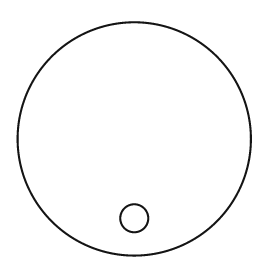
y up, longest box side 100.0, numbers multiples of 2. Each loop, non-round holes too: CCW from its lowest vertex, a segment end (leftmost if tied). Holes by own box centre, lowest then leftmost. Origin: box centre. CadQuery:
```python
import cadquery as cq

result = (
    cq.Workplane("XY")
    .moveTo(0.0, 0.0)
    .circle(50.0)
    .moveTo(0.0, -34.0)
    .circle(6.0)
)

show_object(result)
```